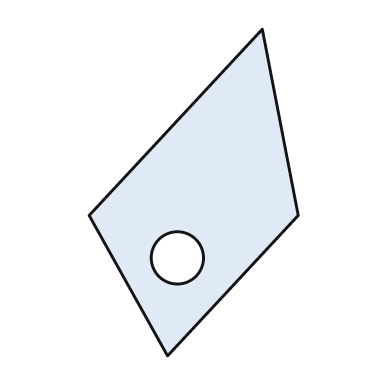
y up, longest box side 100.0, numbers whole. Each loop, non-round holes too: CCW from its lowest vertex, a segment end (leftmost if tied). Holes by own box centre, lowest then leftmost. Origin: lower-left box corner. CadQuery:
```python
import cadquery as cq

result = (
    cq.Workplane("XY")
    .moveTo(24.0, 0.0)
    .lineTo(64.0, 43.0)
    .lineTo(53.0, 100.0)
    .lineTo(0.0, 43.0)
    .close()
    .moveTo(27.0, 30.0)
    .circle(8.0)
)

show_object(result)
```